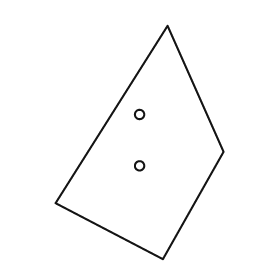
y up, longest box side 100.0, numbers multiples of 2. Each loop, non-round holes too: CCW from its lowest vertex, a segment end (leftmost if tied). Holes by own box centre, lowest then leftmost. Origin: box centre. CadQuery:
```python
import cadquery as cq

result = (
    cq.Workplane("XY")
    .moveTo(10.0, -50.0)
    .lineTo(36.0, -4.0)
    .lineTo(12.0, 50.0)
    .lineTo(-36.0, -26.0)
    .close()
    .moveTo(0.0, -10.0)
    .circle(2.0)
    .moveTo(0.0, 12.0)
    .circle(2.0)
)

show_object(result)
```